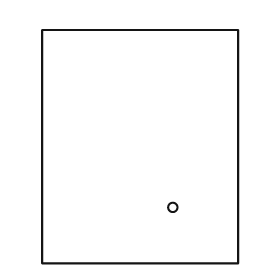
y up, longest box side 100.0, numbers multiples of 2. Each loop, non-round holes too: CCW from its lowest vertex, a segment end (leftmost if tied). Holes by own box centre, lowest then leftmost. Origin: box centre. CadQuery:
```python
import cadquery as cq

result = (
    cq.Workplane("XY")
    .moveTo(-42.0, -50.0)
    .lineTo(42.0, -50.0)
    .lineTo(42.0, 50.0)
    .lineTo(-42.0, 50.0)
    .close()
    .moveTo(14.0, -26.0)
    .circle(2.0)
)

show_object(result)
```